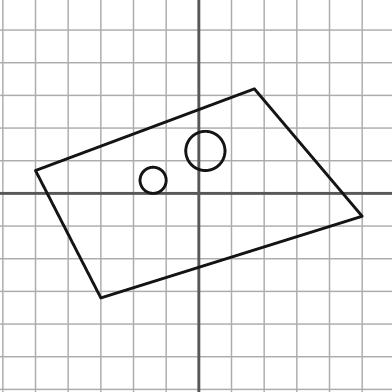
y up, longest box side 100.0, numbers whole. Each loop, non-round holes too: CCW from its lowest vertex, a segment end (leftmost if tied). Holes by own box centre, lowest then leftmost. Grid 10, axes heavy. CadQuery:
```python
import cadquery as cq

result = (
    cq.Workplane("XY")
    .moveTo(-30.0, -32.0)
    .lineTo(50.0, -7.0)
    .lineTo(17.0, 32.0)
    .lineTo(-50.0, 7.0)
    .close()
    .moveTo(-14.0, 4.0)
    .circle(4.0)
    .moveTo(2.0, 13.0)
    .circle(6.0)
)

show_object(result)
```